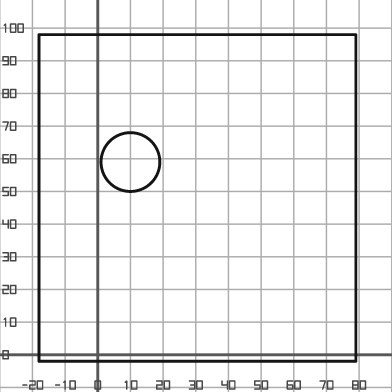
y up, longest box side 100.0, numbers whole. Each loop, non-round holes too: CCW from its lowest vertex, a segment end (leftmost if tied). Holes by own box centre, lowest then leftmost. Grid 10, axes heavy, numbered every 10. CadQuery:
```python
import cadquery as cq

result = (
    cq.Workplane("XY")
    .moveTo(-18.0, -2.0)
    .lineTo(79.0, -2.0)
    .lineTo(79.0, 98.0)
    .lineTo(-18.0, 98.0)
    .close()
    .moveTo(10.0, 59.0)
    .circle(9.0)
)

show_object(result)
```